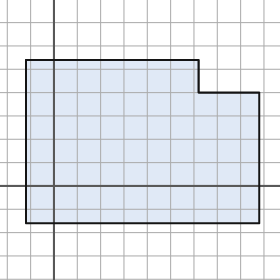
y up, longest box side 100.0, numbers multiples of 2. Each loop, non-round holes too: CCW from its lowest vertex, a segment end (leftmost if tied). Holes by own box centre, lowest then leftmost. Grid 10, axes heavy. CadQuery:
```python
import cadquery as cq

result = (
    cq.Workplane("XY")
    .moveTo(-12.0, -16.0)
    .lineTo(88.0, -16.0)
    .lineTo(88.0, 40.0)
    .lineTo(62.0, 40.0)
    .lineTo(62.0, 54.0)
    .lineTo(-12.0, 54.0)
    .close()
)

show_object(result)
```